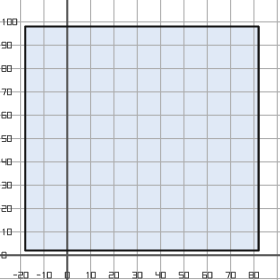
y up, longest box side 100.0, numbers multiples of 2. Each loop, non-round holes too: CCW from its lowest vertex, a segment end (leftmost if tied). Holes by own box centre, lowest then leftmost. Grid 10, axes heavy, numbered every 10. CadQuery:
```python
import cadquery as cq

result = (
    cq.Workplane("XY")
    .moveTo(-18.0, 2.0)
    .lineTo(82.0, 2.0)
    .lineTo(82.0, 98.0)
    .lineTo(-18.0, 98.0)
    .close()
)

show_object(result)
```